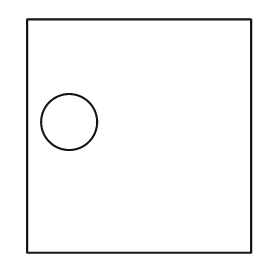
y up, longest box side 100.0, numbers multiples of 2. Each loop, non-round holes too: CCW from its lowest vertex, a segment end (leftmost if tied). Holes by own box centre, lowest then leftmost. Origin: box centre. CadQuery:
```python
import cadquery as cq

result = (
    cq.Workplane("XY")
    .moveTo(-48.0, -50.0)
    .lineTo(48.0, -50.0)
    .lineTo(48.0, 50.0)
    .lineTo(-48.0, 50.0)
    .close()
    .moveTo(-30.0, 6.0)
    .circle(12.0)
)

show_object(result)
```